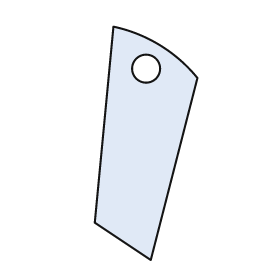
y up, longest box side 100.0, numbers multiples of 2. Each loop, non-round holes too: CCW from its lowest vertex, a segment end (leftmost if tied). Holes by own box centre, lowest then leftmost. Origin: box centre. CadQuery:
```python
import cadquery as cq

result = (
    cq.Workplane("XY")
    .moveTo(2.0, -50.0)
    .lineTo(22.0, 28.0)
    .threePointArc((6.0, 42.0), (-14.0, 50.0))
    .lineTo(-22.0, -34.0)
    .close()
    .moveTo(0.0, 32.0)
    .circle(6.0)
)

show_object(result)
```